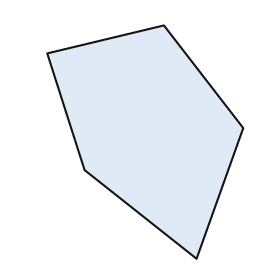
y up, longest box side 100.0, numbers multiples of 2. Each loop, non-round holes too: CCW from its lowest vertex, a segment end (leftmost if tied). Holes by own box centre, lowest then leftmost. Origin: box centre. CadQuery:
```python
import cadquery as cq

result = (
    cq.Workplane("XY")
    .moveTo(22.0, -50.0)
    .lineTo(42.0, 6.0)
    .lineTo(8.0, 50.0)
    .lineTo(-42.0, 38.0)
    .lineTo(-26.0, -12.0)
    .close()
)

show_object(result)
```